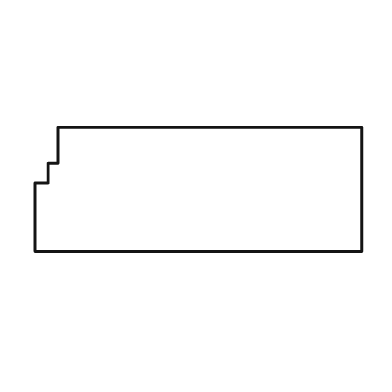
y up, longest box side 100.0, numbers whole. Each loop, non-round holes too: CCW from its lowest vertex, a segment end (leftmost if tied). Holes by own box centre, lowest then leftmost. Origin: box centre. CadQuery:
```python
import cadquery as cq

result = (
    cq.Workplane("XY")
    .moveTo(-50.0, -19.0)
    .lineTo(50.0, -19.0)
    .lineTo(50.0, 19.0)
    .lineTo(-43.0, 19.0)
    .lineTo(-43.0, 8.0)
    .lineTo(-46.0, 8.0)
    .lineTo(-46.0, 2.0)
    .lineTo(-50.0, 2.0)
    .close()
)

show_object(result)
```